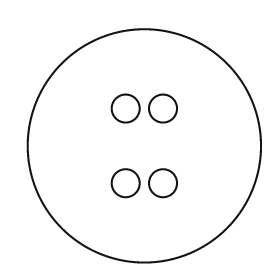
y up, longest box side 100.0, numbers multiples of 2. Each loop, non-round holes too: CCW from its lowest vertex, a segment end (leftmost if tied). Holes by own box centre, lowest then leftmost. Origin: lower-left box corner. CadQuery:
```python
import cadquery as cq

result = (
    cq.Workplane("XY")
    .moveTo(50.0, 50.0)
    .circle(50.0)
    .moveTo(42.0, 34.0)
    .circle(6.0)
    .moveTo(58.0, 34.0)
    .circle(6.0)
    .moveTo(42.0, 66.0)
    .circle(6.0)
    .moveTo(58.0, 66.0)
    .circle(6.0)
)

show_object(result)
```